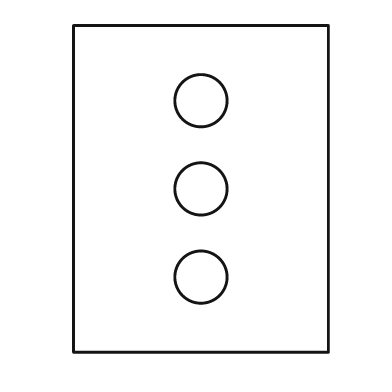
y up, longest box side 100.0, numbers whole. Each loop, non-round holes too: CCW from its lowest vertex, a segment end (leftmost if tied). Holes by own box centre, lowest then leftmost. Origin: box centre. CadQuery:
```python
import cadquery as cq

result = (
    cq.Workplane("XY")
    .moveTo(-39.0, -50.0)
    .lineTo(39.0, -50.0)
    .lineTo(39.0, 50.0)
    .lineTo(-39.0, 50.0)
    .close()
    .moveTo(0.0, -27.0)
    .circle(8.0)
    .moveTo(0.0, 0.0)
    .circle(8.0)
    .moveTo(0.0, 27.0)
    .circle(8.0)
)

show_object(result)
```